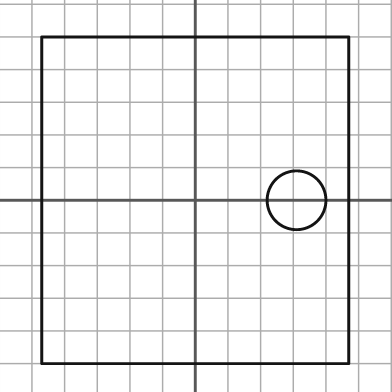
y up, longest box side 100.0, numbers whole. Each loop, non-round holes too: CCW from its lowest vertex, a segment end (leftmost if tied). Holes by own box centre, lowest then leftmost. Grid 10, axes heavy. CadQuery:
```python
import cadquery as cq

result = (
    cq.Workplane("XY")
    .moveTo(-47.0, -50.0)
    .lineTo(47.0, -50.0)
    .lineTo(47.0, 50.0)
    .lineTo(-47.0, 50.0)
    .close()
    .moveTo(31.0, 0.0)
    .circle(9.0)
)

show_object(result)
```